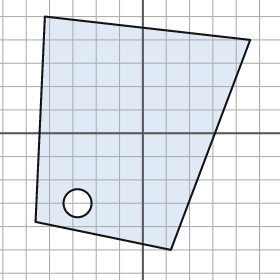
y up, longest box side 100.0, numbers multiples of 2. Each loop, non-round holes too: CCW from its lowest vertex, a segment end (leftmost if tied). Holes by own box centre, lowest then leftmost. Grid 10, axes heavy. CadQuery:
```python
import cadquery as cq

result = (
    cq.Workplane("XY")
    .moveTo(12.0, -50.0)
    .lineTo(46.0, 40.0)
    .lineTo(-42.0, 50.0)
    .lineTo(-46.0, -38.0)
    .close()
    .moveTo(-28.0, -30.0)
    .circle(6.0)
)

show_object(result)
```